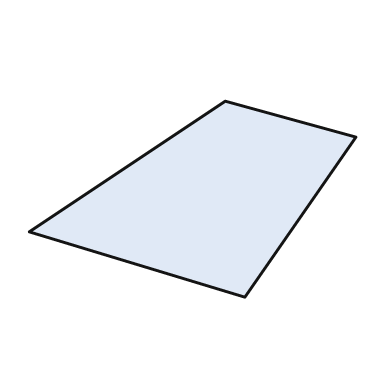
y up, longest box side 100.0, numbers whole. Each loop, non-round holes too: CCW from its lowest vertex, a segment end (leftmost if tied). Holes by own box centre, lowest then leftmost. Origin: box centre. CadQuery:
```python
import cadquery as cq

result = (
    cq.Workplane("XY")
    .moveTo(16.0, -30.0)
    .lineTo(50.0, 19.0)
    .lineTo(10.0, 30.0)
    .lineTo(-50.0, -10.0)
    .close()
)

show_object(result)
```